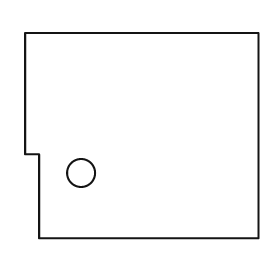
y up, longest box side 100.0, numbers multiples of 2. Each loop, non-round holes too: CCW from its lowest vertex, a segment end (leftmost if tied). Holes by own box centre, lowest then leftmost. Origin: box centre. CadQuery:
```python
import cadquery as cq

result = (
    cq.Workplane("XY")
    .moveTo(-44.0, -44.0)
    .lineTo(50.0, -44.0)
    .lineTo(50.0, 44.0)
    .lineTo(-50.0, 44.0)
    .lineTo(-50.0, -8.0)
    .lineTo(-44.0, -8.0)
    .close()
    .moveTo(-26.0, -16.0)
    .circle(6.0)
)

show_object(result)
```